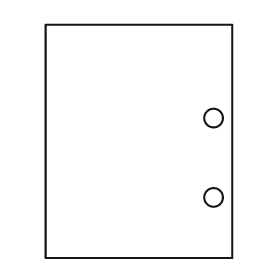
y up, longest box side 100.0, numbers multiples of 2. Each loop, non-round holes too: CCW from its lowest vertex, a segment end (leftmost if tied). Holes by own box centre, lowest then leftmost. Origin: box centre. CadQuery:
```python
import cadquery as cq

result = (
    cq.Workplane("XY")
    .moveTo(-40.0, -50.0)
    .lineTo(40.0, -50.0)
    .lineTo(40.0, 50.0)
    .lineTo(-40.0, 50.0)
    .close()
    .moveTo(32.0, -24.0)
    .circle(4.0)
    .moveTo(32.0, 10.0)
    .circle(4.0)
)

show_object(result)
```